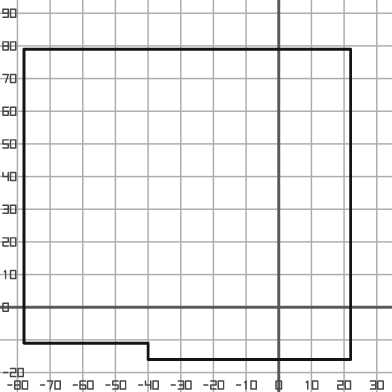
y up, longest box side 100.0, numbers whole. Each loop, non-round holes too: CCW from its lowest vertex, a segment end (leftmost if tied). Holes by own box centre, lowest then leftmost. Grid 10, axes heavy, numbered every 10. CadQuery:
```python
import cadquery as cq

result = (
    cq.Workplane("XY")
    .moveTo(-40.0, -16.0)
    .lineTo(22.0, -16.0)
    .lineTo(22.0, 79.0)
    .lineTo(-78.0, 79.0)
    .lineTo(-78.0, -11.0)
    .lineTo(-40.0, -11.0)
    .close()
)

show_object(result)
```